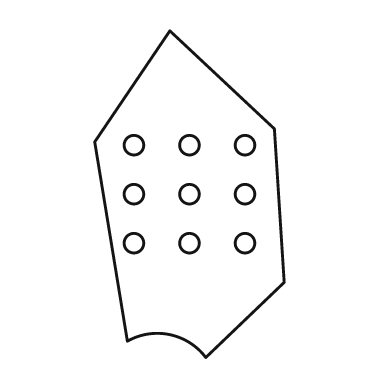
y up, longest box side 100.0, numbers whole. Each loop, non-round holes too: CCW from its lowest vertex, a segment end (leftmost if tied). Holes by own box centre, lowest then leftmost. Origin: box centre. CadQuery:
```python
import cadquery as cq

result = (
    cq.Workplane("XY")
    .moveTo(5.0, -50.0)
    .lineTo(29.0, -27.0)
    .lineTo(26.0, 20.0)
    .lineTo(-6.0, 50.0)
    .lineTo(-29.0, 16.0)
    .lineTo(-19.0, -45.0)
    .threePointArc((-6.0, -43.0), (5.0, -50.0))
    .close()
    .moveTo(-17.0, -15.0)
    .circle(3.0)
    .moveTo(0.0, -15.0)
    .circle(3.0)
    .moveTo(17.0, -15.0)
    .circle(3.0)
    .moveTo(-17.0, 0.0)
    .circle(3.0)
    .moveTo(0.0, 0.0)
    .circle(3.0)
    .moveTo(17.0, 0.0)
    .circle(3.0)
    .moveTo(-17.0, 15.0)
    .circle(3.0)
    .moveTo(0.0, 15.0)
    .circle(3.0)
    .moveTo(17.0, 15.0)
    .circle(3.0)
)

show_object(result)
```